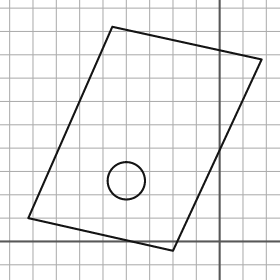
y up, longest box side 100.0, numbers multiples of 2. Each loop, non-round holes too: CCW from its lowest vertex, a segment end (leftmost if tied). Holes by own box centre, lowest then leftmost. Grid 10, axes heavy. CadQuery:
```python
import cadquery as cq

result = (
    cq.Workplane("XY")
    .moveTo(-20.0, -4.0)
    .lineTo(18.0, 78.0)
    .lineTo(-46.0, 92.0)
    .lineTo(-82.0, 10.0)
    .close()
    .moveTo(-40.0, 26.0)
    .circle(8.0)
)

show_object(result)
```